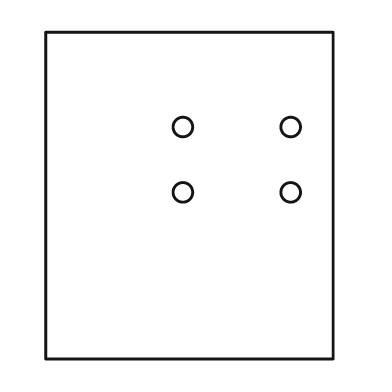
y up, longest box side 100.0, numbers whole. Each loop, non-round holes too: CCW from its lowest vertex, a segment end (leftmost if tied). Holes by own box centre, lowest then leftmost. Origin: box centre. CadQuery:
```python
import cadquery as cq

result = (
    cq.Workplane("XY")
    .moveTo(-44.0, -50.0)
    .lineTo(44.0, -50.0)
    .lineTo(44.0, 50.0)
    .lineTo(-44.0, 50.0)
    .close()
    .moveTo(-2.0, 1.0)
    .circle(3.0)
    .moveTo(31.0, 1.0)
    .circle(3.0)
    .moveTo(-2.0, 21.0)
    .circle(3.0)
    .moveTo(31.0, 21.0)
    .circle(3.0)
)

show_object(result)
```